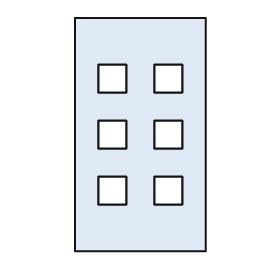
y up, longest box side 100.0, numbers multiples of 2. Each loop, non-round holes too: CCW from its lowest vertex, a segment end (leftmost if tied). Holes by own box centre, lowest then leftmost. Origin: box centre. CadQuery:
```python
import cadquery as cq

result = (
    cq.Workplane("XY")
    .moveTo(-28.0, -50.0)
    .lineTo(28.0, -50.0)
    .lineTo(28.0, 50.0)
    .lineTo(-28.0, 50.0)
    .close()
    .moveTo(-18.0, -30.0)
    .lineTo(-6.0, -30.0)
    .lineTo(-6.0, -18.0)
    .lineTo(-18.0, -18.0)
    .close()
    .moveTo(6.0, -30.0)
    .lineTo(18.0, -30.0)
    .lineTo(18.0, -18.0)
    .lineTo(6.0, -18.0)
    .close()
    .moveTo(-18.0, -6.0)
    .lineTo(-6.0, -6.0)
    .lineTo(-6.0, 6.0)
    .lineTo(-18.0, 6.0)
    .close()
    .moveTo(6.0, -6.0)
    .lineTo(18.0, -6.0)
    .lineTo(18.0, 6.0)
    .lineTo(6.0, 6.0)
    .close()
    .moveTo(-18.0, 18.0)
    .lineTo(-6.0, 18.0)
    .lineTo(-6.0, 30.0)
    .lineTo(-18.0, 30.0)
    .close()
    .moveTo(6.0, 18.0)
    .lineTo(18.0, 18.0)
    .lineTo(18.0, 30.0)
    .lineTo(6.0, 30.0)
    .close()
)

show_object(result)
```